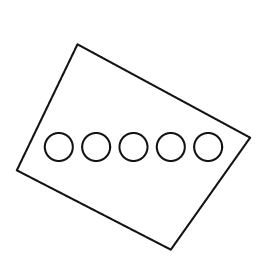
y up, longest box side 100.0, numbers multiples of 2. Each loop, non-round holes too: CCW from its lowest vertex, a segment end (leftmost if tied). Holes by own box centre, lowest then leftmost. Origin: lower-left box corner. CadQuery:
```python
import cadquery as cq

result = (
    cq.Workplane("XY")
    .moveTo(66.0, 0.0)
    .lineTo(100.0, 48.0)
    .lineTo(26.0, 88.0)
    .lineTo(0.0, 34.0)
    .close()
    .moveTo(18.0, 44.0)
    .circle(6.0)
    .moveTo(34.0, 44.0)
    .circle(6.0)
    .moveTo(50.0, 44.0)
    .circle(6.0)
    .moveTo(66.0, 44.0)
    .circle(6.0)
    .moveTo(82.0, 44.0)
    .circle(6.0)
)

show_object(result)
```